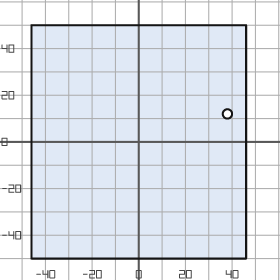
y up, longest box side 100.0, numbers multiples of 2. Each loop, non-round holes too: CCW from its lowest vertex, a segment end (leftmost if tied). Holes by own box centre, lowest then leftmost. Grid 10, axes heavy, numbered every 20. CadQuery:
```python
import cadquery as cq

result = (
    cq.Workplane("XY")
    .moveTo(-46.0, -50.0)
    .lineTo(46.0, -50.0)
    .lineTo(46.0, 50.0)
    .lineTo(-46.0, 50.0)
    .close()
    .moveTo(38.0, 12.0)
    .circle(2.0)
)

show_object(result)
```